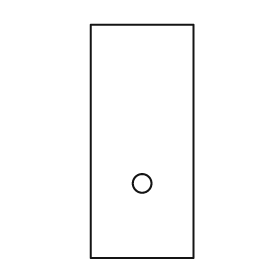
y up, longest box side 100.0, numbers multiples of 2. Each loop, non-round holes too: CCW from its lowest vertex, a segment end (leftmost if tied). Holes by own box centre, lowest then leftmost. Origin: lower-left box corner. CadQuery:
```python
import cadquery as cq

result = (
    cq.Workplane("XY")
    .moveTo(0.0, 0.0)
    .lineTo(44.0, 0.0)
    .lineTo(44.0, 100.0)
    .lineTo(0.0, 100.0)
    .close()
    .moveTo(22.0, 32.0)
    .circle(4.0)
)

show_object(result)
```